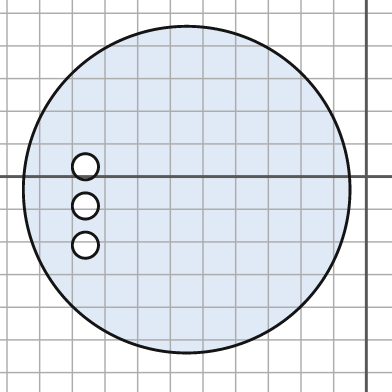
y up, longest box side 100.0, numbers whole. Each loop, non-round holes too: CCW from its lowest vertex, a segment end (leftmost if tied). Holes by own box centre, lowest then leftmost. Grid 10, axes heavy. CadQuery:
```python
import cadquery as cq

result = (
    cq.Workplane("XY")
    .moveTo(-55.0, -4.0)
    .circle(50.0)
    .moveTo(-86.0, -21.0)
    .circle(4.0)
    .moveTo(-86.0, -9.0)
    .circle(4.0)
    .moveTo(-86.0, 3.0)
    .circle(4.0)
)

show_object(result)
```